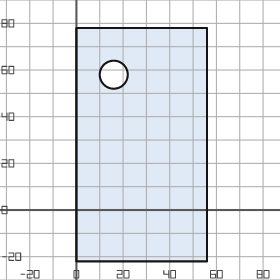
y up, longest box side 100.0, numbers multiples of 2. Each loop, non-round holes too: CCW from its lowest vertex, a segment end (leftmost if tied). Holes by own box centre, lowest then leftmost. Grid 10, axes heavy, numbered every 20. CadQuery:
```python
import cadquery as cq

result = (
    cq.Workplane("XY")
    .moveTo(0.0, -22.0)
    .lineTo(56.0, -22.0)
    .lineTo(56.0, 78.0)
    .lineTo(0.0, 78.0)
    .close()
    .moveTo(16.0, 58.0)
    .circle(6.0)
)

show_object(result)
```